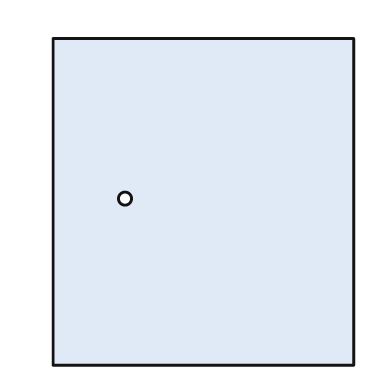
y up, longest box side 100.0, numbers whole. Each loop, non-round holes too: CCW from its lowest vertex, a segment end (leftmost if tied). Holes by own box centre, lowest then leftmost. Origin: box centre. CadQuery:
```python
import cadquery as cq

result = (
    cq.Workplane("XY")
    .moveTo(-46.0, -50.0)
    .lineTo(46.0, -50.0)
    .lineTo(46.0, 50.0)
    .lineTo(-46.0, 50.0)
    .close()
    .moveTo(-24.0, 1.0)
    .circle(2.0)
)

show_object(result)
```